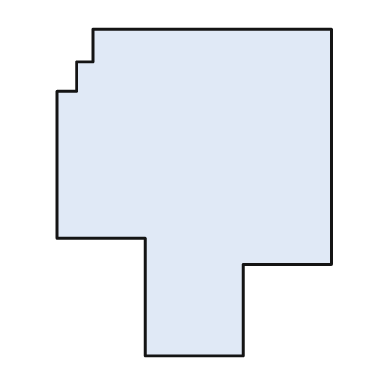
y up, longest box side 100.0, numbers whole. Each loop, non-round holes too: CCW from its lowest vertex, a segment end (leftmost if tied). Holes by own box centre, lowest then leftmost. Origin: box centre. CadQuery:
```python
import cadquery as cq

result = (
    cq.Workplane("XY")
    .moveTo(-15.0, -50.0)
    .lineTo(15.0, -50.0)
    .lineTo(15.0, -22.0)
    .lineTo(42.0, -22.0)
    .lineTo(42.0, 50.0)
    .lineTo(-31.0, 50.0)
    .lineTo(-31.0, 40.0)
    .lineTo(-36.0, 40.0)
    .lineTo(-36.0, 31.0)
    .lineTo(-42.0, 31.0)
    .lineTo(-42.0, -14.0)
    .lineTo(-15.0, -14.0)
    .close()
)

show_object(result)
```